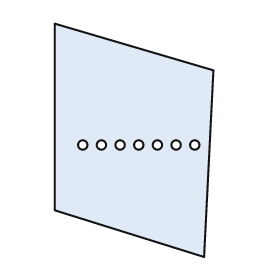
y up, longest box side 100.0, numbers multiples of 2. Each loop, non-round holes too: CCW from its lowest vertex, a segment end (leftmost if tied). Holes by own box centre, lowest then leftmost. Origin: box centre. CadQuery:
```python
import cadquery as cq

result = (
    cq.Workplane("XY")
    .moveTo(30.0, -50.0)
    .lineTo(34.0, 30.0)
    .lineTo(-34.0, 50.0)
    .lineTo(-34.0, -30.0)
    .close()
    .moveTo(-22.0, -2.0)
    .circle(2.0)
    .moveTo(-14.0, -2.0)
    .circle(2.0)
    .moveTo(-6.0, -2.0)
    .circle(2.0)
    .moveTo(2.0, -2.0)
    .circle(2.0)
    .moveTo(10.0, -2.0)
    .circle(2.0)
    .moveTo(18.0, -2.0)
    .circle(2.0)
    .moveTo(26.0, -2.0)
    .circle(2.0)
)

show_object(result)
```